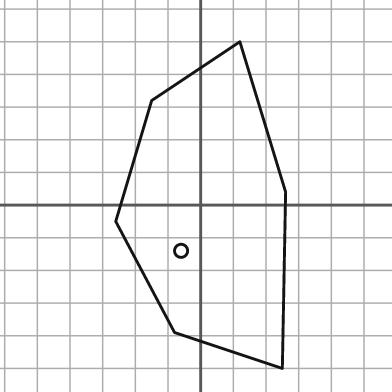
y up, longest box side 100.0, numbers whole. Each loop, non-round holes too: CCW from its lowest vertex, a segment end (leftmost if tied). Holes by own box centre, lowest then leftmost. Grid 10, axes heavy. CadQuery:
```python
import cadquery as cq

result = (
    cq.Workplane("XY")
    .moveTo(25.0, -50.0)
    .lineTo(26.0, 4.0)
    .lineTo(12.0, 50.0)
    .lineTo(-15.0, 32.0)
    .lineTo(-26.0, -5.0)
    .lineTo(-8.0, -39.0)
    .close()
    .moveTo(-6.0, -14.0)
    .circle(2.0)
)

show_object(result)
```